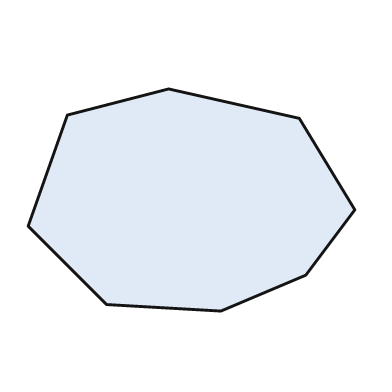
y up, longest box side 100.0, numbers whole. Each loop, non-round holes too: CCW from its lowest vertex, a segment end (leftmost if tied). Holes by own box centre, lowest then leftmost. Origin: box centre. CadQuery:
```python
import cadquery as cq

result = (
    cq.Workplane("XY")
    .moveTo(9.0, -34.0)
    .lineTo(35.0, -23.0)
    .lineTo(50.0, -3.0)
    .lineTo(33.0, 25.0)
    .lineTo(-7.0, 34.0)
    .lineTo(-38.0, 26.0)
    .lineTo(-50.0, -8.0)
    .lineTo(-26.0, -32.0)
    .close()
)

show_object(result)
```